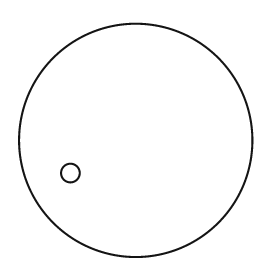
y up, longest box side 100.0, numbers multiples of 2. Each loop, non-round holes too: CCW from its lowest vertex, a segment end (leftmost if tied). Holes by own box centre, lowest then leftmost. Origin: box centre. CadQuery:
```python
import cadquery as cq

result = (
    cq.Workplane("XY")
    .moveTo(0.0, 0.0)
    .circle(50.0)
    .moveTo(-28.0, -14.0)
    .circle(4.0)
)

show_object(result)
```